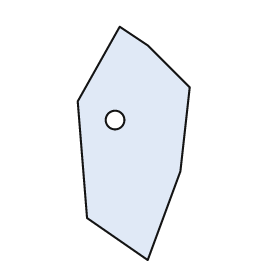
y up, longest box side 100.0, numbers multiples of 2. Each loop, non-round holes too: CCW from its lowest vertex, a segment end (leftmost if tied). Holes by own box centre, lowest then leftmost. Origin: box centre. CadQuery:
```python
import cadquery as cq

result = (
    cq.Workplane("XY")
    .moveTo(6.0, -50.0)
    .lineTo(20.0, -12.0)
    .lineTo(24.0, 24.0)
    .lineTo(6.0, 42.0)
    .lineTo(-6.0, 50.0)
    .lineTo(-24.0, 18.0)
    .lineTo(-20.0, -32.0)
    .close()
    .moveTo(-8.0, 10.0)
    .circle(4.0)
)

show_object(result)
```